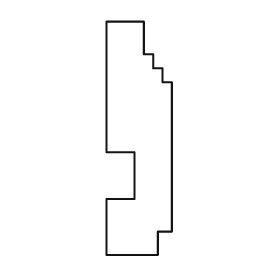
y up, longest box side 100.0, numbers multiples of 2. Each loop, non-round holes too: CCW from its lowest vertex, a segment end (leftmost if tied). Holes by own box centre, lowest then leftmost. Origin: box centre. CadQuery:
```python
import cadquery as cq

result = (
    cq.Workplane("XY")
    .moveTo(-14.0, -50.0)
    .lineTo(8.0, -50.0)
    .lineTo(8.0, -40.0)
    .lineTo(14.0, -40.0)
    .lineTo(14.0, 24.0)
    .lineTo(10.0, 24.0)
    .lineTo(10.0, 30.0)
    .lineTo(6.0, 30.0)
    .lineTo(6.0, 36.0)
    .lineTo(2.0, 36.0)
    .lineTo(2.0, 50.0)
    .lineTo(-14.0, 50.0)
    .lineTo(-14.0, -6.0)
    .lineTo(-2.0, -6.0)
    .lineTo(-2.0, -26.0)
    .lineTo(-14.0, -26.0)
    .close()
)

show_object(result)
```